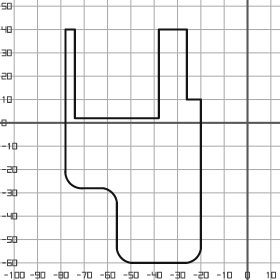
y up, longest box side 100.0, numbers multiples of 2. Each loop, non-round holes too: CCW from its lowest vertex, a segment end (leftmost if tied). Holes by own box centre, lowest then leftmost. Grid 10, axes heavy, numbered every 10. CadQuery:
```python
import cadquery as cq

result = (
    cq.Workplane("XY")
    .moveTo(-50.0, -60.0)
    .lineTo(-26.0, -60.0)
    .threePointArc((-22.0, -58.0), (-20.0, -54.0))
    .lineTo(-20.0, 10.0)
    .lineTo(-26.0, 10.0)
    .lineTo(-26.0, 40.0)
    .lineTo(-38.0, 40.0)
    .lineTo(-38.0, 2.0)
    .lineTo(-74.0, 2.0)
    .lineTo(-74.0, 40.0)
    .lineTo(-78.0, 40.0)
    .lineTo(-78.0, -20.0)
    .threePointArc((-76.0, -26.0), (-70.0, -28.0))
    .lineTo(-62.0, -28.0)
    .threePointArc((-58.0, -30.0), (-56.0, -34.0))
    .lineTo(-56.0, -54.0)
    .threePointArc((-54.0, -58.0), (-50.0, -60.0))
    .close()
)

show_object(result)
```